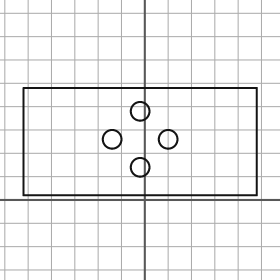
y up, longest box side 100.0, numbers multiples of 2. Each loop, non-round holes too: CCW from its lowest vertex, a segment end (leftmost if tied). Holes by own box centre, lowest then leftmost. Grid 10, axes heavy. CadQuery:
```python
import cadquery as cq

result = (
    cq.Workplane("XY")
    .moveTo(-52.0, 2.0)
    .lineTo(48.0, 2.0)
    .lineTo(48.0, 48.0)
    .lineTo(-52.0, 48.0)
    .close()
    .moveTo(-2.0, 14.0)
    .circle(4.0)
    .moveTo(-14.0, 26.0)
    .circle(4.0)
    .moveTo(10.0, 26.0)
    .circle(4.0)
    .moveTo(-2.0, 38.0)
    .circle(4.0)
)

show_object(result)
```